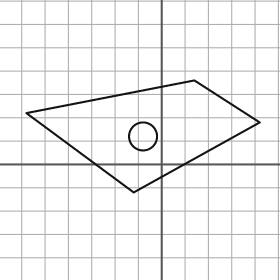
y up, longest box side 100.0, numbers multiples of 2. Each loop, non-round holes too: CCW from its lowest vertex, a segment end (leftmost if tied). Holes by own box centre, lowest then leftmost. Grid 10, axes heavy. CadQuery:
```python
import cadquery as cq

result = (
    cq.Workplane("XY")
    .moveTo(-12.0, -12.0)
    .lineTo(42.0, 18.0)
    .lineTo(14.0, 36.0)
    .lineTo(-58.0, 22.0)
    .close()
    .moveTo(-8.0, 12.0)
    .circle(6.0)
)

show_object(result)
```